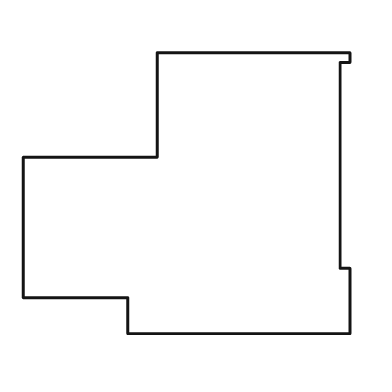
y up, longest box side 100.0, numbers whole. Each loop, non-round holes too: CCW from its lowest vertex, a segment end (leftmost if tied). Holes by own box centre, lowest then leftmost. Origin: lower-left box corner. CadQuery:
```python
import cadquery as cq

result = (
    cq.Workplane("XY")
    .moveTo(32.0, 0.0)
    .lineTo(100.0, 0.0)
    .lineTo(100.0, 20.0)
    .lineTo(97.0, 20.0)
    .lineTo(97.0, 83.0)
    .lineTo(100.0, 83.0)
    .lineTo(100.0, 86.0)
    .lineTo(41.0, 86.0)
    .lineTo(41.0, 54.0)
    .lineTo(0.0, 54.0)
    .lineTo(0.0, 11.0)
    .lineTo(32.0, 11.0)
    .close()
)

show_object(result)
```